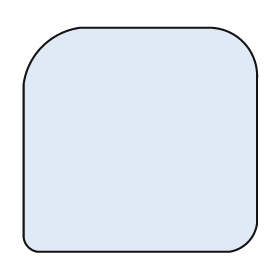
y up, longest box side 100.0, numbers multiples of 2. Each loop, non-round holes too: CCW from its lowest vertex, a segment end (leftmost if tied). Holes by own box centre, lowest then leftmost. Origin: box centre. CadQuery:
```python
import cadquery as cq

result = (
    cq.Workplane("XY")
    .moveTo(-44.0, -48.0)
    .lineTo(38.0, -48.0)
    .threePointArc((46.0, -44.0), (50.0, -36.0))
    .lineTo(50.0, 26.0)
    .threePointArc((44.0, 42.0), (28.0, 48.0))
    .lineTo(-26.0, 48.0)
    .threePointArc((-42.0, 40.0), (-50.0, 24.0))
    .lineTo(-50.0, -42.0)
    .threePointArc((-48.0, -46.0), (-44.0, -48.0))
    .close()
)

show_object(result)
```